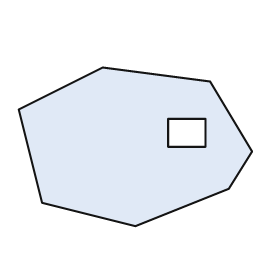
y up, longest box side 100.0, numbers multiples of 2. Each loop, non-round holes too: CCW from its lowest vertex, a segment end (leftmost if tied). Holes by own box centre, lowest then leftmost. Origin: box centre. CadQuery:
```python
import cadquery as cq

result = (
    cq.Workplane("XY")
    .moveTo(0.0, -34.0)
    .lineTo(40.0, -18.0)
    .lineTo(50.0, -2.0)
    .lineTo(32.0, 28.0)
    .lineTo(-14.0, 34.0)
    .lineTo(-50.0, 16.0)
    .lineTo(-40.0, -24.0)
    .close()
    .moveTo(14.0, 0.0)
    .lineTo(30.0, 0.0)
    .lineTo(30.0, 12.0)
    .lineTo(14.0, 12.0)
    .close()
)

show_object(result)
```